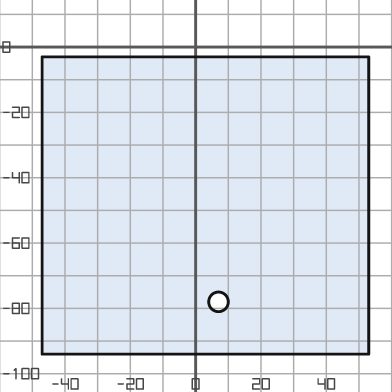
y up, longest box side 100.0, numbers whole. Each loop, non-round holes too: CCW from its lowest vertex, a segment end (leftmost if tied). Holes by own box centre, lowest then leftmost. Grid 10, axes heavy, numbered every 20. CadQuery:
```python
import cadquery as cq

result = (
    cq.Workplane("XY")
    .moveTo(-47.0, -94.0)
    .lineTo(53.0, -94.0)
    .lineTo(53.0, -3.0)
    .lineTo(-47.0, -3.0)
    .close()
    .moveTo(7.0, -78.0)
    .circle(3.0)
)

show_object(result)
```